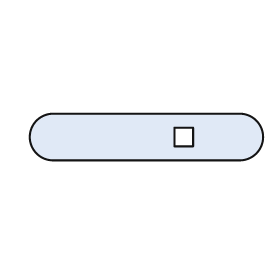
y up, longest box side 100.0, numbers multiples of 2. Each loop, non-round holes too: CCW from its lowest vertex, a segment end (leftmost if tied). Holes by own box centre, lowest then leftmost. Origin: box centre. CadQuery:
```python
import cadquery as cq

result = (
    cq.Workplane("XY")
    .moveTo(-40.0, -10.0)
    .lineTo(40.0, -10.0)
    .threePointArc((50.0, 0.0), (40.0, 10.0))
    .lineTo(-40.0, 10.0)
    .threePointArc((-50.0, 0.0), (-40.0, -10.0))
    .close()
    .moveTo(12.0, -4.0)
    .lineTo(20.0, -4.0)
    .lineTo(20.0, 4.0)
    .lineTo(12.0, 4.0)
    .close()
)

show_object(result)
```